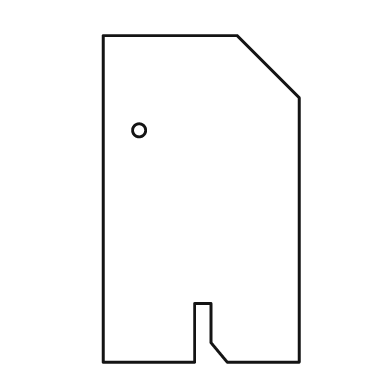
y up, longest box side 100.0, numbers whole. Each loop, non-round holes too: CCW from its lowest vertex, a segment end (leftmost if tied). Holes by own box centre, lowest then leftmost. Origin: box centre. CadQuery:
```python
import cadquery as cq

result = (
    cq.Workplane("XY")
    .moveTo(-30.0, -50.0)
    .lineTo(-2.0, -50.0)
    .lineTo(-2.0, -32.0)
    .lineTo(3.0, -32.0)
    .lineTo(3.0, -44.0)
    .lineTo(8.0, -50.0)
    .lineTo(30.0, -50.0)
    .lineTo(30.0, 31.0)
    .lineTo(11.0, 50.0)
    .lineTo(-30.0, 50.0)
    .close()
    .moveTo(-19.0, 21.0)
    .circle(2.0)
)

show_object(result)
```